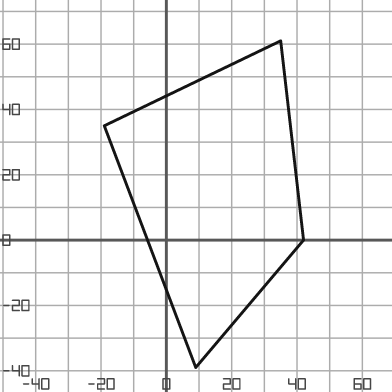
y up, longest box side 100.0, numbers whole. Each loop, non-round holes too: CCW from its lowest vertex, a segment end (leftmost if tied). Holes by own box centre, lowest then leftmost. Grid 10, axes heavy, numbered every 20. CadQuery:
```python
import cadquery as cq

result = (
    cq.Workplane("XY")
    .moveTo(9.0, -39.0)
    .lineTo(42.0, 0.0)
    .lineTo(35.0, 61.0)
    .lineTo(-19.0, 35.0)
    .close()
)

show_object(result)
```